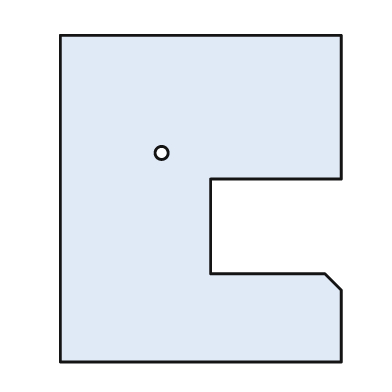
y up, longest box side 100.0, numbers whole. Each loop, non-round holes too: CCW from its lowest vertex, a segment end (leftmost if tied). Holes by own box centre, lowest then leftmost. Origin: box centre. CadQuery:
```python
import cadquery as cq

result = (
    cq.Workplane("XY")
    .moveTo(-43.0, -50.0)
    .lineTo(43.0, -50.0)
    .lineTo(43.0, -28.0)
    .lineTo(38.0, -23.0)
    .lineTo(3.0, -23.0)
    .lineTo(3.0, 6.0)
    .lineTo(43.0, 6.0)
    .lineTo(43.0, 50.0)
    .lineTo(-43.0, 50.0)
    .close()
    .moveTo(-12.0, 14.0)
    .circle(2.0)
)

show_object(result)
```